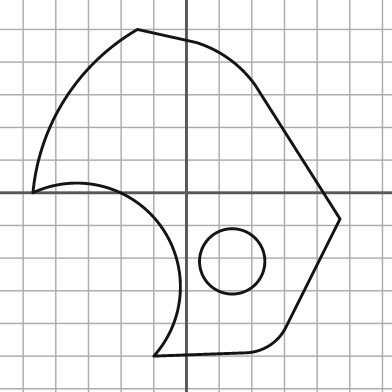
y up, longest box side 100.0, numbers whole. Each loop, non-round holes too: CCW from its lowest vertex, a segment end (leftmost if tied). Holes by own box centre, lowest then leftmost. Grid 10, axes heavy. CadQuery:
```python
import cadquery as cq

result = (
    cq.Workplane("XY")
    .moveTo(-10.0, -50.0)
    .lineTo(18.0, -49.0)
    .threePointArc((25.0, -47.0), (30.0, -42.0))
    .lineTo(47.0, -8.0)
    .lineTo(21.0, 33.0)
    .threePointArc((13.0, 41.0), (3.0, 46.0))
    .lineTo(-15.0, 50.0)
    .threePointArc((-37.0, 29.0), (-47.0, 0.0))
    .threePointArc((-8.0, -10.0), (-10.0, -50.0))
    .close()
    .moveTo(14.0, -21.0)
    .circle(10.0)
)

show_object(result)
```